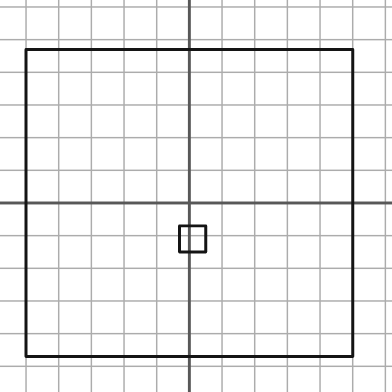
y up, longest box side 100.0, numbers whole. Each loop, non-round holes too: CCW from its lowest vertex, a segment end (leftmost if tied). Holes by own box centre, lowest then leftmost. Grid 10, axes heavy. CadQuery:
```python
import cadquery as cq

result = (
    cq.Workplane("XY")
    .moveTo(-50.0, -47.0)
    .lineTo(50.0, -47.0)
    .lineTo(50.0, 47.0)
    .lineTo(-50.0, 47.0)
    .close()
    .moveTo(-3.0, -15.0)
    .lineTo(5.0, -15.0)
    .lineTo(5.0, -7.0)
    .lineTo(-3.0, -7.0)
    .close()
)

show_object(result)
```